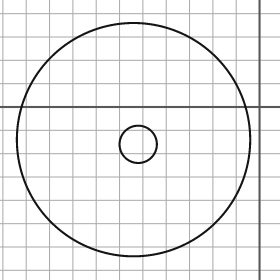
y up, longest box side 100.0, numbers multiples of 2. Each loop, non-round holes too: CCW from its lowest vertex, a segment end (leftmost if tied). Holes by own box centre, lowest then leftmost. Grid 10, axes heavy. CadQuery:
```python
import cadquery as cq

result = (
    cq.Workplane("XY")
    .moveTo(-54.0, -14.0)
    .circle(50.0)
    .moveTo(-52.0, -16.0)
    .circle(8.0)
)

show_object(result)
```